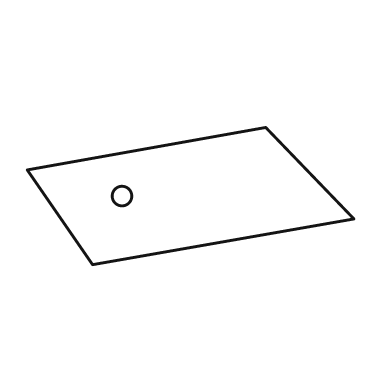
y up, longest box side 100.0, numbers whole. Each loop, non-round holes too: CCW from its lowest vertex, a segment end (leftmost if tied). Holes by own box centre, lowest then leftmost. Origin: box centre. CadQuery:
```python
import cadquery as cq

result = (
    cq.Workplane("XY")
    .moveTo(-30.0, -21.0)
    .lineTo(50.0, -7.0)
    .lineTo(23.0, 21.0)
    .lineTo(-50.0, 8.0)
    .close()
    .moveTo(-21.0, 0.0)
    .circle(3.0)
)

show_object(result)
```